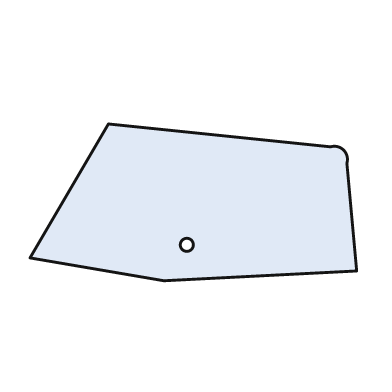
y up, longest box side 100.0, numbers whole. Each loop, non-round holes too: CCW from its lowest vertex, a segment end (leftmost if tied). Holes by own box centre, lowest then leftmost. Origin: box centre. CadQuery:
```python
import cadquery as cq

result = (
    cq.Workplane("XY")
    .moveTo(-9.0, -24.0)
    .lineTo(50.0, -21.0)
    .lineTo(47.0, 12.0)
    .threePointArc((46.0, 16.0), (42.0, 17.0))
    .lineTo(-26.0, 24.0)
    .lineTo(-50.0, -17.0)
    .close()
    .moveTo(-2.0, -13.0)
    .circle(2.0)
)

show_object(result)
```